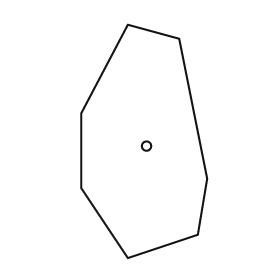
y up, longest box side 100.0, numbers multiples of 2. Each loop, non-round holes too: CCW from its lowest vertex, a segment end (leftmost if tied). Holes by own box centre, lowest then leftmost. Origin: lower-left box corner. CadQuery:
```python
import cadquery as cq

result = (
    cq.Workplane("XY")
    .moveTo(20.0, 0.0)
    .lineTo(50.0, 10.0)
    .lineTo(54.0, 34.0)
    .lineTo(42.0, 94.0)
    .lineTo(20.0, 100.0)
    .lineTo(0.0, 62.0)
    .lineTo(0.0, 30.0)
    .close()
    .moveTo(28.0, 48.0)
    .circle(2.0)
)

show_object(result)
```